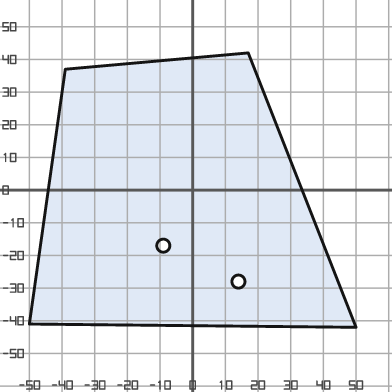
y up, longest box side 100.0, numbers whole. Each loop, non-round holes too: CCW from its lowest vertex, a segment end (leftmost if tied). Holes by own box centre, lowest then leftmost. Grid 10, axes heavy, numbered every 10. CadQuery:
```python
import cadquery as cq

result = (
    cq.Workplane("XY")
    .moveTo(50.0, -42.0)
    .lineTo(17.0, 42.0)
    .lineTo(-39.0, 37.0)
    .lineTo(-50.0, -41.0)
    .close()
    .moveTo(14.0, -28.0)
    .circle(2.0)
    .moveTo(-9.0, -17.0)
    .circle(2.0)
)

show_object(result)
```